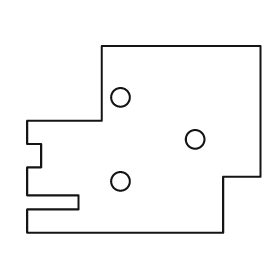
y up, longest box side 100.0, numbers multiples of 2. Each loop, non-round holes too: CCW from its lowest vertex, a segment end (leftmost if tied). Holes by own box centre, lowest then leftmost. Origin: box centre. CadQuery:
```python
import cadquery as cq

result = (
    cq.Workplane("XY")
    .moveTo(-50.0, -40.0)
    .lineTo(34.0, -40.0)
    .lineTo(34.0, -16.0)
    .lineTo(50.0, -16.0)
    .lineTo(50.0, 40.0)
    .lineTo(-18.0, 40.0)
    .lineTo(-18.0, 8.0)
    .lineTo(-50.0, 8.0)
    .lineTo(-50.0, -2.0)
    .lineTo(-44.0, -2.0)
    .lineTo(-44.0, -12.0)
    .lineTo(-50.0, -12.0)
    .lineTo(-50.0, -24.0)
    .lineTo(-28.0, -24.0)
    .lineTo(-28.0, -30.0)
    .lineTo(-50.0, -30.0)
    .close()
    .moveTo(-10.0, -18.0)
    .circle(4.0)
    .moveTo(22.0, 0.0)
    .circle(4.0)
    .moveTo(-10.0, 18.0)
    .circle(4.0)
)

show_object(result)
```